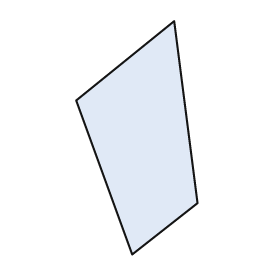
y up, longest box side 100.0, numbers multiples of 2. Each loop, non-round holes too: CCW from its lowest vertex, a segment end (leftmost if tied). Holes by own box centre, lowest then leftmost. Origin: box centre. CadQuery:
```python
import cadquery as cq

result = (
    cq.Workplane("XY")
    .moveTo(-2.0, -50.0)
    .lineTo(26.0, -28.0)
    .lineTo(16.0, 50.0)
    .lineTo(-26.0, 16.0)
    .close()
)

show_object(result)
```